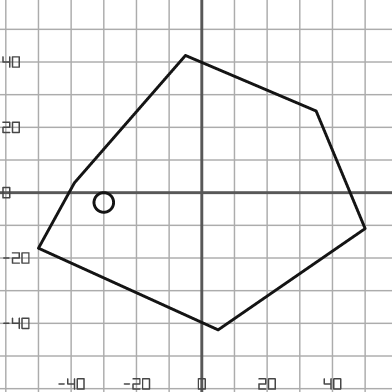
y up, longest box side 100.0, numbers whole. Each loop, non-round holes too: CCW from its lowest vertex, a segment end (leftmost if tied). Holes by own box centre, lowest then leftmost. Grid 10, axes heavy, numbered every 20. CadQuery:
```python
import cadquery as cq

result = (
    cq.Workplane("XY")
    .moveTo(5.0, -42.0)
    .lineTo(50.0, -11.0)
    .lineTo(35.0, 25.0)
    .lineTo(-5.0, 42.0)
    .lineTo(-39.0, 3.0)
    .lineTo(-50.0, -17.0)
    .close()
    .moveTo(-30.0, -3.0)
    .circle(3.0)
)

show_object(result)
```